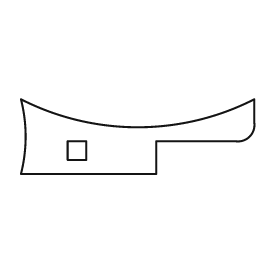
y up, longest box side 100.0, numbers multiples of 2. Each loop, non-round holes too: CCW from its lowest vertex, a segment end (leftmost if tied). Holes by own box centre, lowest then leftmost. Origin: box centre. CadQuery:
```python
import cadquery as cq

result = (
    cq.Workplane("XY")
    .moveTo(-50.0, -16.0)
    .lineTo(8.0, -16.0)
    .lineTo(8.0, -2.0)
    .lineTo(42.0, -2.0)
    .threePointArc((48.0, 0.0), (50.0, 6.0))
    .lineTo(50.0, 16.0)
    .threePointArc((0.0, 4.0), (-50.0, 16.0))
    .threePointArc((-48.0, 0.0), (-50.0, -16.0))
    .close()
    .moveTo(-30.0, -10.0)
    .lineTo(-22.0, -10.0)
    .lineTo(-22.0, -2.0)
    .lineTo(-30.0, -2.0)
    .close()
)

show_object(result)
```